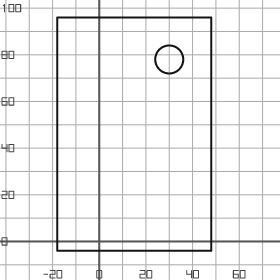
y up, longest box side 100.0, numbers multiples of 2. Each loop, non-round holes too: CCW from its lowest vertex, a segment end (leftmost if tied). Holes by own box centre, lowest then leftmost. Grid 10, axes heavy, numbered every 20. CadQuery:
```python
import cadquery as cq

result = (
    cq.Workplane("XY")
    .moveTo(-18.0, -4.0)
    .lineTo(48.0, -4.0)
    .lineTo(48.0, 96.0)
    .lineTo(-18.0, 96.0)
    .close()
    .moveTo(30.0, 78.0)
    .circle(6.0)
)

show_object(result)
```